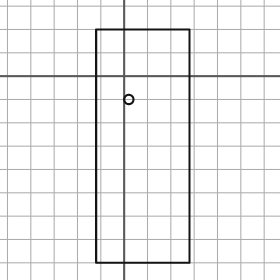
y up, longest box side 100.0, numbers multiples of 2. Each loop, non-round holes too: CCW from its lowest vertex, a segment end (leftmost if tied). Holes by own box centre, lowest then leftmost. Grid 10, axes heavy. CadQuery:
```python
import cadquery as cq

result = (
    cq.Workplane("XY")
    .moveTo(-12.0, -80.0)
    .lineTo(28.0, -80.0)
    .lineTo(28.0, 20.0)
    .lineTo(-12.0, 20.0)
    .close()
    .moveTo(2.0, -10.0)
    .circle(2.0)
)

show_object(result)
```